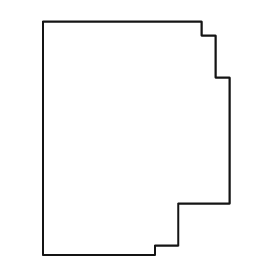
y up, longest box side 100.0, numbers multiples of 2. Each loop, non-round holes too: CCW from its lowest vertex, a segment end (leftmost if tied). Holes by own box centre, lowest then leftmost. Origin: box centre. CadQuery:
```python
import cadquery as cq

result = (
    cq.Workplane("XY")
    .moveTo(-40.0, -50.0)
    .lineTo(8.0, -50.0)
    .lineTo(8.0, -46.0)
    .lineTo(18.0, -46.0)
    .lineTo(18.0, -28.0)
    .lineTo(40.0, -28.0)
    .lineTo(40.0, 26.0)
    .lineTo(34.0, 26.0)
    .lineTo(34.0, 44.0)
    .lineTo(28.0, 44.0)
    .lineTo(28.0, 50.0)
    .lineTo(-40.0, 50.0)
    .close()
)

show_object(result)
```